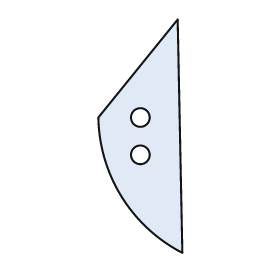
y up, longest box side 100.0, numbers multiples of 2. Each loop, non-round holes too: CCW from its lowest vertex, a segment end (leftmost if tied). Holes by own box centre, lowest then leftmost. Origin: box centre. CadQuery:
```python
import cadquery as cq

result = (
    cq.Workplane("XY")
    .moveTo(18.0, -50.0)
    .lineTo(16.0, 50.0)
    .lineTo(-18.0, 8.0)
    .threePointArc((-8.0, -26.0), (18.0, -50.0))
    .close()
    .moveTo(0.0, -8.0)
    .circle(4.0)
    .moveTo(0.0, 8.0)
    .circle(4.0)
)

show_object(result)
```